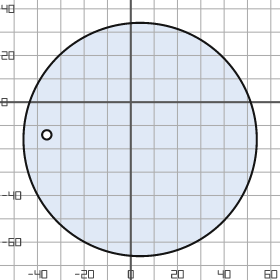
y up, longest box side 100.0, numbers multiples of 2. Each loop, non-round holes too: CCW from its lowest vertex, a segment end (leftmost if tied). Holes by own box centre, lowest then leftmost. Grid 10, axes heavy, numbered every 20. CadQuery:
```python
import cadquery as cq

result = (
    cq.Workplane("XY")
    .moveTo(4.0, -16.0)
    .circle(50.0)
    .moveTo(-36.0, -14.0)
    .circle(2.0)
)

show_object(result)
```